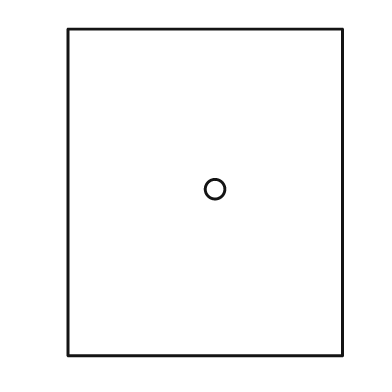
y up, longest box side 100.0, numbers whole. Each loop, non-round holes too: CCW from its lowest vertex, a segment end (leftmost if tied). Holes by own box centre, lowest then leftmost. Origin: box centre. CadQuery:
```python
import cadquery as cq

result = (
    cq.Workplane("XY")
    .moveTo(-42.0, -50.0)
    .lineTo(42.0, -50.0)
    .lineTo(42.0, 50.0)
    .lineTo(-42.0, 50.0)
    .close()
    .moveTo(3.0, 1.0)
    .circle(3.0)
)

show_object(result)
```